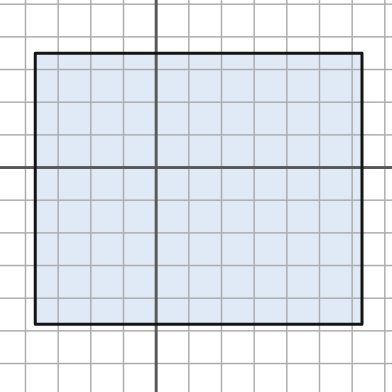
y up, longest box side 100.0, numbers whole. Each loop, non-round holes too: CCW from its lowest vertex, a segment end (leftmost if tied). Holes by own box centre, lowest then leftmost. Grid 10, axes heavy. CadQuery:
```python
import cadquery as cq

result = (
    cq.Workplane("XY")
    .moveTo(-37.0, -48.0)
    .lineTo(63.0, -48.0)
    .lineTo(63.0, 35.0)
    .lineTo(-37.0, 35.0)
    .close()
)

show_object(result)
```